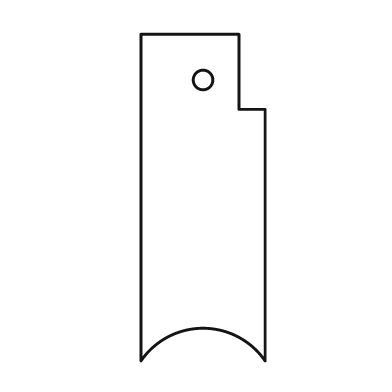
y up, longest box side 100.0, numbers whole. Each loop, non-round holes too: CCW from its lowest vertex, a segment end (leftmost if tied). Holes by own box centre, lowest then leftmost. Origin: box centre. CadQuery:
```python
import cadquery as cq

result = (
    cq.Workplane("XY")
    .moveTo(-19.0, -50.0)
    .threePointArc((0.0, -40.0), (19.0, -50.0))
    .lineTo(19.0, 27.0)
    .lineTo(11.0, 27.0)
    .lineTo(11.0, 50.0)
    .lineTo(-19.0, 50.0)
    .close()
    .moveTo(0.0, 36.0)
    .circle(3.0)
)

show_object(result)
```